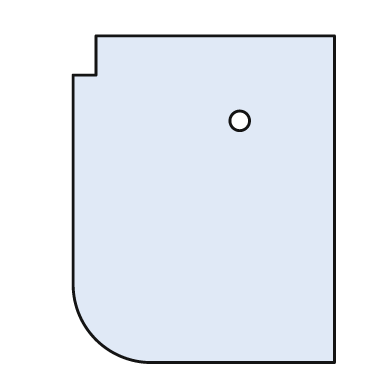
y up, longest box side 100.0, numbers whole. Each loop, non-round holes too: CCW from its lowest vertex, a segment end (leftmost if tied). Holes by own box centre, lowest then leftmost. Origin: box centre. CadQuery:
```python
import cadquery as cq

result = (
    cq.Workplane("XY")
    .moveTo(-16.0, -50.0)
    .lineTo(40.0, -50.0)
    .lineTo(40.0, 50.0)
    .lineTo(-33.0, 50.0)
    .lineTo(-33.0, 38.0)
    .lineTo(-40.0, 38.0)
    .lineTo(-40.0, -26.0)
    .threePointArc((-33.0, -43.0), (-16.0, -50.0))
    .close()
    .moveTo(11.0, 24.0)
    .circle(3.0)
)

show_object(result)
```